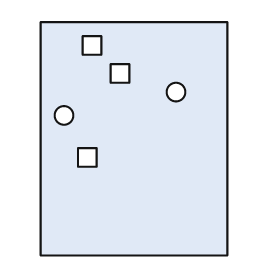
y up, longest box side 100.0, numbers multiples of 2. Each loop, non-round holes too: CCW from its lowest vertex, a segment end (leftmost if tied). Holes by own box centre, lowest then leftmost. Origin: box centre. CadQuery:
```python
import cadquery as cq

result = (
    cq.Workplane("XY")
    .moveTo(-40.0, -50.0)
    .lineTo(40.0, -50.0)
    .lineTo(40.0, 50.0)
    .lineTo(-40.0, 50.0)
    .close()
    .moveTo(-24.0, -12.0)
    .lineTo(-16.0, -12.0)
    .lineTo(-16.0, -4.0)
    .lineTo(-24.0, -4.0)
    .close()
    .moveTo(-30.0, 10.0)
    .circle(4.0)
    .moveTo(18.0, 20.0)
    .circle(4.0)
    .moveTo(-10.0, 24.0)
    .lineTo(-2.0, 24.0)
    .lineTo(-2.0, 32.0)
    .lineTo(-10.0, 32.0)
    .close()
    .moveTo(-22.0, 36.0)
    .lineTo(-14.0, 36.0)
    .lineTo(-14.0, 44.0)
    .lineTo(-22.0, 44.0)
    .close()
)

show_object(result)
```